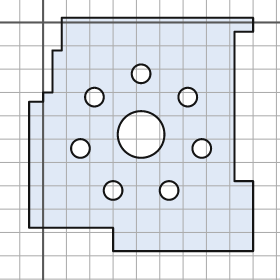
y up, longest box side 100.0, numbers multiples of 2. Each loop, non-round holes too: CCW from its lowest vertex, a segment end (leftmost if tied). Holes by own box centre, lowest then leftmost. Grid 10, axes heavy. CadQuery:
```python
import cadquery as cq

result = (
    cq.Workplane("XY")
    .moveTo(30.0, -98.0)
    .lineTo(90.0, -98.0)
    .lineTo(90.0, -68.0)
    .lineTo(82.0, -68.0)
    .lineTo(82.0, -4.0)
    .lineTo(90.0, -4.0)
    .lineTo(90.0, 2.0)
    .lineTo(8.0, 2.0)
    .lineTo(8.0, -12.0)
    .lineTo(4.0, -12.0)
    .lineTo(4.0, -30.0)
    .lineTo(0.0, -30.0)
    .lineTo(0.0, -34.0)
    .lineTo(-6.0, -34.0)
    .lineTo(-6.0, -88.0)
    .lineTo(30.0, -88.0)
    .close()
    .moveTo(30.0, -72.0)
    .circle(4.0)
    .moveTo(54.0, -72.0)
    .circle(4.0)
    .moveTo(16.0, -54.0)
    .circle(4.0)
    .moveTo(68.0, -54.0)
    .circle(4.0)
    .moveTo(42.0, -48.0)
    .circle(10.0)
    .moveTo(22.0, -32.0)
    .circle(4.0)
    .moveTo(62.0, -32.0)
    .circle(4.0)
    .moveTo(42.0, -22.0)
    .circle(4.0)
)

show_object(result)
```